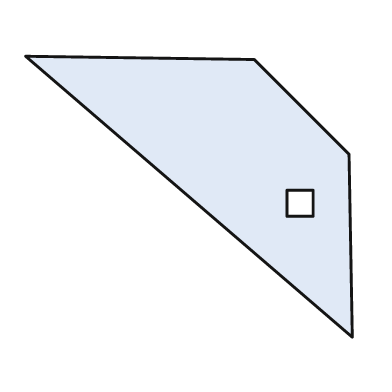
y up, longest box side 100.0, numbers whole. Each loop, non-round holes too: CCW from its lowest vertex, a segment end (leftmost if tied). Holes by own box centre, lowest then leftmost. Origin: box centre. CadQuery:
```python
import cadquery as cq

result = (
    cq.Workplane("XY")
    .moveTo(50.0, -43.0)
    .lineTo(49.0, 13.0)
    .lineTo(20.0, 42.0)
    .lineTo(-50.0, 43.0)
    .close()
    .moveTo(30.0, -6.0)
    .lineTo(38.0, -6.0)
    .lineTo(38.0, 2.0)
    .lineTo(30.0, 2.0)
    .close()
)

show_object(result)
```